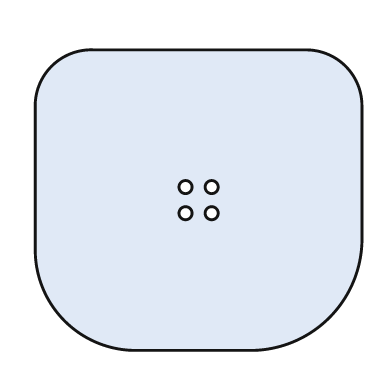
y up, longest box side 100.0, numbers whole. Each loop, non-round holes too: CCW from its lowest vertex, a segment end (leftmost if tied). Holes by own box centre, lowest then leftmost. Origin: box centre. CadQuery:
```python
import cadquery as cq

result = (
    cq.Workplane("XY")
    .moveTo(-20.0, -46.0)
    .lineTo(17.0, -46.0)
    .threePointArc((40.0, -36.0), (50.0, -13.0))
    .lineTo(50.0, 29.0)
    .threePointArc((45.0, 41.0), (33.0, 46.0))
    .lineTo(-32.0, 46.0)
    .threePointArc((-45.0, 41.0), (-50.0, 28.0))
    .lineTo(-50.0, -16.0)
    .threePointArc((-41.0, -37.0), (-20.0, -46.0))
    .close()
    .moveTo(-4.0, -4.0)
    .circle(2.0)
    .moveTo(4.0, -4.0)
    .circle(2.0)
    .moveTo(-4.0, 4.0)
    .circle(2.0)
    .moveTo(4.0, 4.0)
    .circle(2.0)
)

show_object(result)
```